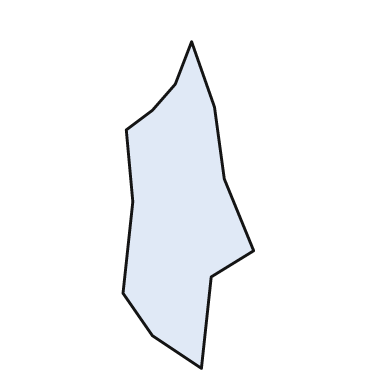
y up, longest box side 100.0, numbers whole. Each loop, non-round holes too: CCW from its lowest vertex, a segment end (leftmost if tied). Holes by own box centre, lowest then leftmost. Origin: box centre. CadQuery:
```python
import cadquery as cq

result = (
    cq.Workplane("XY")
    .moveTo(4.0, -50.0)
    .lineTo(7.0, -22.0)
    .lineTo(20.0, -14.0)
    .lineTo(11.0, 8.0)
    .lineTo(8.0, 30.0)
    .lineTo(1.0, 50.0)
    .lineTo(-4.0, 37.0)
    .lineTo(-11.0, 29.0)
    .lineTo(-19.0, 23.0)
    .lineTo(-17.0, 1.0)
    .lineTo(-20.0, -27.0)
    .lineTo(-11.0, -40.0)
    .close()
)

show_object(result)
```